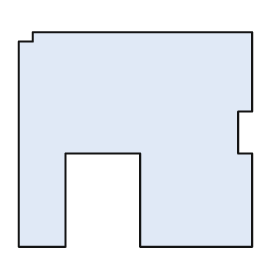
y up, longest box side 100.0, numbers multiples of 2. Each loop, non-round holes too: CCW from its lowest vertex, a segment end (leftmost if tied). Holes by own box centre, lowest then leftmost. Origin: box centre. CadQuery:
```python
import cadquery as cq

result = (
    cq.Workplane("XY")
    .moveTo(-50.0, -46.0)
    .lineTo(-30.0, -46.0)
    .lineTo(-30.0, -6.0)
    .lineTo(2.0, -6.0)
    .lineTo(2.0, -46.0)
    .lineTo(50.0, -46.0)
    .lineTo(50.0, -6.0)
    .lineTo(44.0, -6.0)
    .lineTo(44.0, 12.0)
    .lineTo(50.0, 12.0)
    .lineTo(50.0, 46.0)
    .lineTo(-44.0, 46.0)
    .lineTo(-44.0, 42.0)
    .lineTo(-50.0, 42.0)
    .close()
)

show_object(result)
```